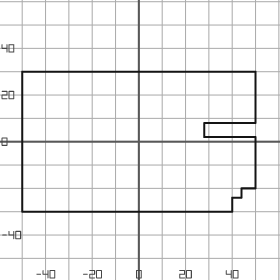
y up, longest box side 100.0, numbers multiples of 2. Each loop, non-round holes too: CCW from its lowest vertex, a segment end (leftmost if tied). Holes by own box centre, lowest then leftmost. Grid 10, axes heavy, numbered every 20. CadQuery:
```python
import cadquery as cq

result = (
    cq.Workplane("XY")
    .moveTo(-50.0, -30.0)
    .lineTo(40.0, -30.0)
    .lineTo(40.0, -24.0)
    .lineTo(44.0, -24.0)
    .lineTo(44.0, -20.0)
    .lineTo(50.0, -20.0)
    .lineTo(50.0, 2.0)
    .lineTo(28.0, 2.0)
    .lineTo(28.0, 8.0)
    .lineTo(50.0, 8.0)
    .lineTo(50.0, 30.0)
    .lineTo(-50.0, 30.0)
    .close()
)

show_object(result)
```